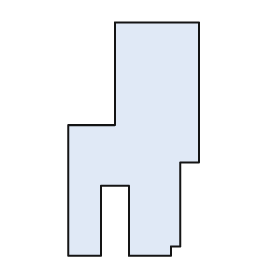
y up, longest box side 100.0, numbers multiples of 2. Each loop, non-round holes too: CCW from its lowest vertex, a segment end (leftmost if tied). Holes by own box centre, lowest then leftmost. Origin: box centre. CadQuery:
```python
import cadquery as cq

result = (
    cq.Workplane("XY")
    .moveTo(-28.0, -50.0)
    .lineTo(-14.0, -50.0)
    .lineTo(-14.0, -20.0)
    .lineTo(-2.0, -20.0)
    .lineTo(-2.0, -50.0)
    .lineTo(16.0, -50.0)
    .lineTo(16.0, -46.0)
    .lineTo(20.0, -46.0)
    .lineTo(20.0, -10.0)
    .lineTo(28.0, -10.0)
    .lineTo(28.0, 50.0)
    .lineTo(-8.0, 50.0)
    .lineTo(-8.0, 6.0)
    .lineTo(-28.0, 6.0)
    .close()
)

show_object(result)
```